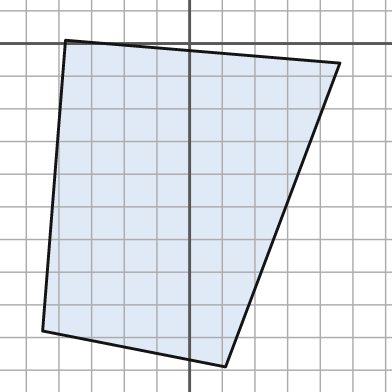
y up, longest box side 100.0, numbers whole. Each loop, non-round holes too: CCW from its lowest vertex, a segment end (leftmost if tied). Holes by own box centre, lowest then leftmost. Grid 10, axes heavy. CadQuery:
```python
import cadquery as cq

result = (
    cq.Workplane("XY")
    .moveTo(11.0, -99.0)
    .lineTo(46.0, -6.0)
    .lineTo(-38.0, 1.0)
    .lineTo(-45.0, -88.0)
    .close()
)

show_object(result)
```